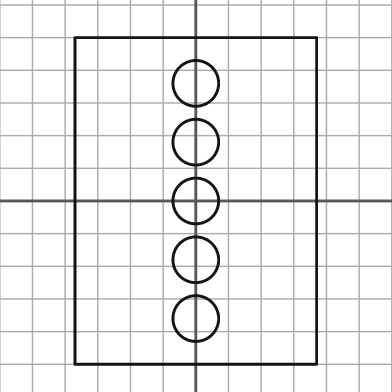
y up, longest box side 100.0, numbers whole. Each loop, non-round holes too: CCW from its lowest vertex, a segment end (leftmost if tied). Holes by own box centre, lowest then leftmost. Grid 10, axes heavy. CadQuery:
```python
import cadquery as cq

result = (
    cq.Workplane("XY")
    .moveTo(-37.0, -50.0)
    .lineTo(37.0, -50.0)
    .lineTo(37.0, 50.0)
    .lineTo(-37.0, 50.0)
    .close()
    .moveTo(0.0, -36.0)
    .circle(7.0)
    .moveTo(0.0, -18.0)
    .circle(7.0)
    .moveTo(0.0, 0.0)
    .circle(7.0)
    .moveTo(0.0, 18.0)
    .circle(7.0)
    .moveTo(0.0, 36.0)
    .circle(7.0)
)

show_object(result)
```